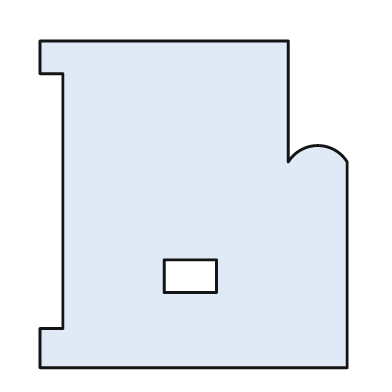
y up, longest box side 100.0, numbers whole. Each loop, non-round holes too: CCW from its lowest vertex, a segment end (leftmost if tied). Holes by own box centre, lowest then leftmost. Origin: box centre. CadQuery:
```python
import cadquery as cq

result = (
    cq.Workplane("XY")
    .moveTo(-47.0, -50.0)
    .lineTo(47.0, -50.0)
    .lineTo(47.0, 13.0)
    .threePointArc((38.0, 18.0), (29.0, 13.0))
    .lineTo(29.0, 50.0)
    .lineTo(-47.0, 50.0)
    .lineTo(-47.0, 40.0)
    .lineTo(-40.0, 40.0)
    .lineTo(-40.0, -38.0)
    .lineTo(-47.0, -38.0)
    .close()
    .moveTo(-9.0, -27.0)
    .lineTo(7.0, -27.0)
    .lineTo(7.0, -17.0)
    .lineTo(-9.0, -17.0)
    .close()
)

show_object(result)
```